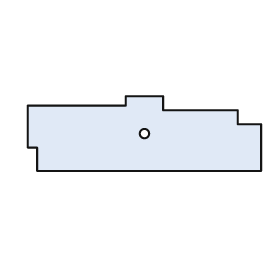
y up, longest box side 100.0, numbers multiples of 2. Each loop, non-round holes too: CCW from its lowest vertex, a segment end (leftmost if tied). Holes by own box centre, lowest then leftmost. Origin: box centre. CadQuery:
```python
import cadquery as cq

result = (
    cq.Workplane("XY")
    .moveTo(-46.0, -16.0)
    .lineTo(50.0, -16.0)
    .lineTo(50.0, 4.0)
    .lineTo(40.0, 4.0)
    .lineTo(40.0, 10.0)
    .lineTo(8.0, 10.0)
    .lineTo(8.0, 16.0)
    .lineTo(-8.0, 16.0)
    .lineTo(-8.0, 12.0)
    .lineTo(-50.0, 12.0)
    .lineTo(-50.0, -6.0)
    .lineTo(-46.0, -6.0)
    .close()
    .moveTo(0.0, 0.0)
    .circle(2.0)
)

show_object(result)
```